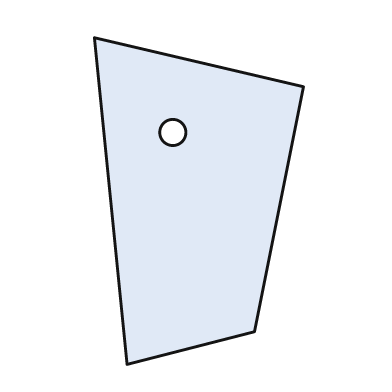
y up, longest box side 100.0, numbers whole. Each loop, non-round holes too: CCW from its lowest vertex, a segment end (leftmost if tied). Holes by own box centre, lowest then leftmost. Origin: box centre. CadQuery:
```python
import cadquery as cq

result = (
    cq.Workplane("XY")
    .moveTo(-22.0, -50.0)
    .lineTo(17.0, -40.0)
    .lineTo(32.0, 35.0)
    .lineTo(-32.0, 50.0)
    .close()
    .moveTo(-8.0, 21.0)
    .circle(4.0)
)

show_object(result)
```